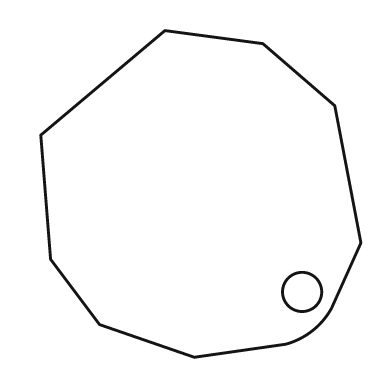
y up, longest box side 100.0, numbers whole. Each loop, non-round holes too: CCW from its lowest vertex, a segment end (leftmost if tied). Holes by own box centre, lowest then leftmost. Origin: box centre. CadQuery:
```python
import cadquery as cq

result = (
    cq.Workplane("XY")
    .moveTo(-2.0, -50.0)
    .lineTo(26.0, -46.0)
    .threePointArc((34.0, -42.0), (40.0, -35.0))
    .lineTo(49.0, -15.0)
    .lineTo(41.0, 27.0)
    .lineTo(19.0, 46.0)
    .lineTo(-11.0, 50.0)
    .lineTo(-49.0, 18.0)
    .lineTo(-46.0, -20.0)
    .lineTo(-31.0, -40.0)
    .close()
    .moveTo(31.0, -30.0)
    .circle(6.0)
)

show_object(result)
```